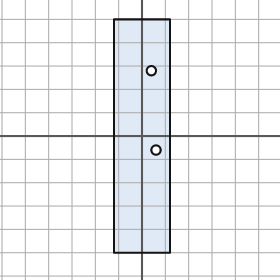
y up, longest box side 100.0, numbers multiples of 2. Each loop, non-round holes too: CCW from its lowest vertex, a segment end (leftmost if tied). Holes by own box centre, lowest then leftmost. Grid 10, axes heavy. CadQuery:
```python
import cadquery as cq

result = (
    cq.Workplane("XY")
    .moveTo(-12.0, -50.0)
    .lineTo(12.0, -50.0)
    .lineTo(12.0, 50.0)
    .lineTo(-12.0, 50.0)
    .close()
    .moveTo(6.0, -6.0)
    .circle(2.0)
    .moveTo(4.0, 28.0)
    .circle(2.0)
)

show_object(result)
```